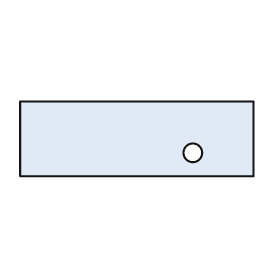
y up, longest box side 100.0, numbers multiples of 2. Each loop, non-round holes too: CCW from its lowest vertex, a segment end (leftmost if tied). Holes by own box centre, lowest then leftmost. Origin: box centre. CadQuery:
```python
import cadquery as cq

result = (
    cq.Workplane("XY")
    .moveTo(-50.0, -16.0)
    .lineTo(50.0, -16.0)
    .lineTo(50.0, 16.0)
    .lineTo(-50.0, 16.0)
    .close()
    .moveTo(24.0, -6.0)
    .circle(4.0)
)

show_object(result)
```